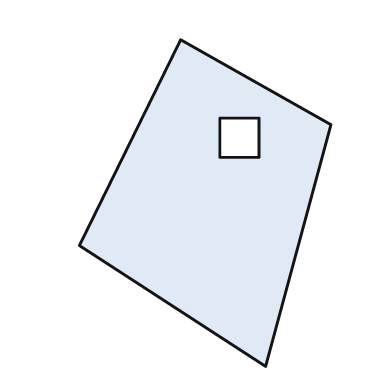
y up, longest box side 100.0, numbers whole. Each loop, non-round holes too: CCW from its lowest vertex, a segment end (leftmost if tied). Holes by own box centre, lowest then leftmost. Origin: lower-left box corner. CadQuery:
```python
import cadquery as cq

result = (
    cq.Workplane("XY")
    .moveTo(57.0, 0.0)
    .lineTo(77.0, 74.0)
    .lineTo(31.0, 100.0)
    .lineTo(0.0, 37.0)
    .close()
    .moveTo(43.0, 64.0)
    .lineTo(55.0, 64.0)
    .lineTo(55.0, 76.0)
    .lineTo(43.0, 76.0)
    .close()
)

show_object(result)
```